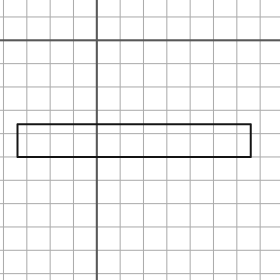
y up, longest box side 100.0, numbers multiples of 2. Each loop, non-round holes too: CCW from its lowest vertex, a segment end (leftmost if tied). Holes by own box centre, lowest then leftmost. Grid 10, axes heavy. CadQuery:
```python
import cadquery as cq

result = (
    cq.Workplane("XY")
    .moveTo(-34.0, -50.0)
    .lineTo(66.0, -50.0)
    .lineTo(66.0, -36.0)
    .lineTo(-34.0, -36.0)
    .close()
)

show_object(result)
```